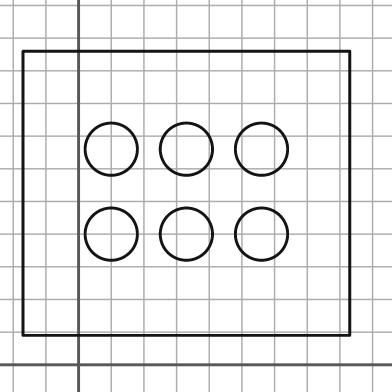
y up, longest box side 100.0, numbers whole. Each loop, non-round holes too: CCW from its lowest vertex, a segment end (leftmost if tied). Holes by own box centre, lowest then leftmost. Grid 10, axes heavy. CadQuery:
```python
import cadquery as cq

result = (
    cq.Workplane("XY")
    .moveTo(-17.0, 9.0)
    .lineTo(83.0, 9.0)
    .lineTo(83.0, 96.0)
    .lineTo(-17.0, 96.0)
    .close()
    .moveTo(10.0, 40.0)
    .circle(8.0)
    .moveTo(33.0, 40.0)
    .circle(8.0)
    .moveTo(56.0, 40.0)
    .circle(8.0)
    .moveTo(10.0, 66.0)
    .circle(8.0)
    .moveTo(33.0, 66.0)
    .circle(8.0)
    .moveTo(56.0, 66.0)
    .circle(8.0)
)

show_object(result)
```